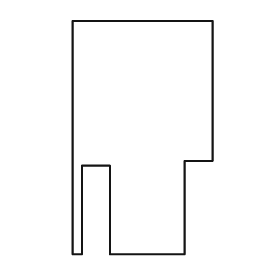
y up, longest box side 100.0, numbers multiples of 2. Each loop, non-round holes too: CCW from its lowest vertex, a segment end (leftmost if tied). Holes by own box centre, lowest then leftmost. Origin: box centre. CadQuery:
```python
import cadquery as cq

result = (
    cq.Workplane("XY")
    .moveTo(-30.0, -50.0)
    .lineTo(-26.0, -50.0)
    .lineTo(-26.0, -12.0)
    .lineTo(-14.0, -12.0)
    .lineTo(-14.0, -50.0)
    .lineTo(18.0, -50.0)
    .lineTo(18.0, -10.0)
    .lineTo(30.0, -10.0)
    .lineTo(30.0, 50.0)
    .lineTo(-30.0, 50.0)
    .close()
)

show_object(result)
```